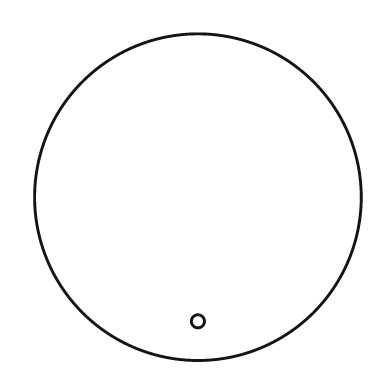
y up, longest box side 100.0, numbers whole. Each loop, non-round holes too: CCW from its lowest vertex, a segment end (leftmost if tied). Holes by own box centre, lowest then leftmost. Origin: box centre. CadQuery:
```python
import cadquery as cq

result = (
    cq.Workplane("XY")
    .moveTo(0.0, 0.0)
    .circle(50.0)
    .moveTo(0.0, -38.0)
    .circle(2.0)
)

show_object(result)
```